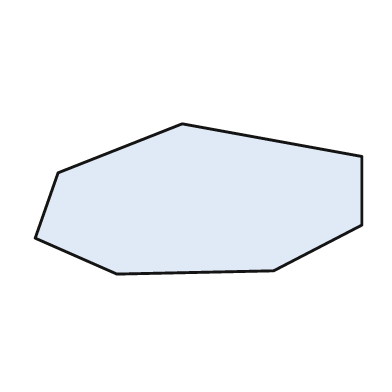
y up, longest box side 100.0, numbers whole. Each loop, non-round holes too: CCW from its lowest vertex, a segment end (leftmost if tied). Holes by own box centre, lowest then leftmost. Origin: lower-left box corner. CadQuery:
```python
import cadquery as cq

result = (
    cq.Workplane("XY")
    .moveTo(25.0, 0.0)
    .lineTo(73.0, 1.0)
    .lineTo(100.0, 15.0)
    .lineTo(100.0, 36.0)
    .lineTo(45.0, 46.0)
    .lineTo(7.0, 31.0)
    .lineTo(0.0, 11.0)
    .close()
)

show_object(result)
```